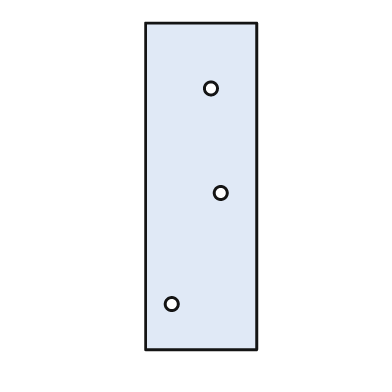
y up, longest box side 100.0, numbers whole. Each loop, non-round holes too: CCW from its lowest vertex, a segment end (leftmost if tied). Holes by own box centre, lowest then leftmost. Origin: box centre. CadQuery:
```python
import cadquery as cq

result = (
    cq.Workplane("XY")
    .moveTo(-17.0, -50.0)
    .lineTo(17.0, -50.0)
    .lineTo(17.0, 50.0)
    .lineTo(-17.0, 50.0)
    .close()
    .moveTo(-9.0, -36.0)
    .circle(2.0)
    .moveTo(6.0, -2.0)
    .circle(2.0)
    .moveTo(3.0, 30.0)
    .circle(2.0)
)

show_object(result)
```